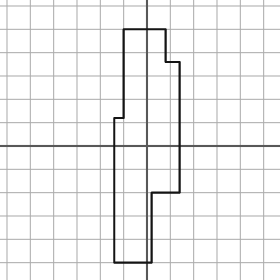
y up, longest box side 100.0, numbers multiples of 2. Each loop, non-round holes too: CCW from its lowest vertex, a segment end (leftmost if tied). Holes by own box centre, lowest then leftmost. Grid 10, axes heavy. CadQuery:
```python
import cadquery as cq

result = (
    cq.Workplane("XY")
    .moveTo(-14.0, -50.0)
    .lineTo(2.0, -50.0)
    .lineTo(2.0, -20.0)
    .lineTo(14.0, -20.0)
    .lineTo(14.0, 36.0)
    .lineTo(8.0, 36.0)
    .lineTo(8.0, 50.0)
    .lineTo(-10.0, 50.0)
    .lineTo(-10.0, 12.0)
    .lineTo(-14.0, 12.0)
    .close()
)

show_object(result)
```